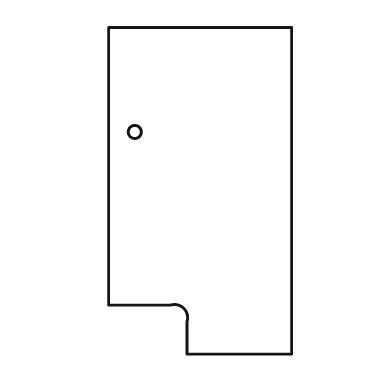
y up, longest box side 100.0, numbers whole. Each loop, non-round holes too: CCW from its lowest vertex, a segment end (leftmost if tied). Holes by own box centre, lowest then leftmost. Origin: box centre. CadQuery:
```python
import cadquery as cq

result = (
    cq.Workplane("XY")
    .moveTo(-4.0, -50.0)
    .lineTo(28.0, -50.0)
    .lineTo(28.0, 50.0)
    .lineTo(-28.0, 50.0)
    .lineTo(-28.0, -35.0)
    .lineTo(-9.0, -35.0)
    .threePointArc((-5.0, -36.0), (-4.0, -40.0))
    .close()
    .moveTo(-20.0, 18.0)
    .circle(2.0)
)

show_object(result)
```